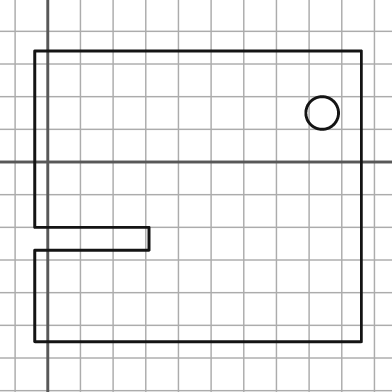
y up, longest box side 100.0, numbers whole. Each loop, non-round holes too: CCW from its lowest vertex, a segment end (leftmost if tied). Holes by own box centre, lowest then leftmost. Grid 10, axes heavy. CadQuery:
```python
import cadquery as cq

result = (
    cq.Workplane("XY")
    .moveTo(-4.0, -55.0)
    .lineTo(96.0, -55.0)
    .lineTo(96.0, 34.0)
    .lineTo(-4.0, 34.0)
    .lineTo(-4.0, -20.0)
    .lineTo(31.0, -20.0)
    .lineTo(31.0, -27.0)
    .lineTo(-4.0, -27.0)
    .close()
    .moveTo(84.0, 15.0)
    .circle(5.0)
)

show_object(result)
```